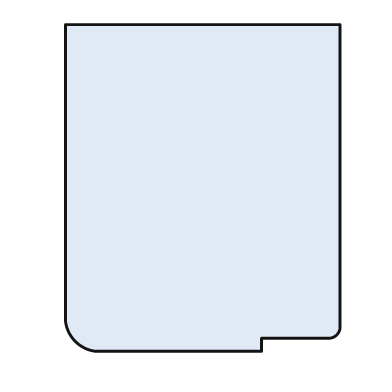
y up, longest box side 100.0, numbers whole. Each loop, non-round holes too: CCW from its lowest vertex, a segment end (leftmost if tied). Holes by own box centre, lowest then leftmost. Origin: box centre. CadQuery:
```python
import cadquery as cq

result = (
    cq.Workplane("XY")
    .moveTo(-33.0, -50.0)
    .lineTo(18.0, -50.0)
    .lineTo(18.0, -46.0)
    .lineTo(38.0, -46.0)
    .threePointArc((41.0, -45.0), (42.0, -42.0))
    .lineTo(42.0, 50.0)
    .lineTo(-42.0, 50.0)
    .lineTo(-42.0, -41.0)
    .threePointArc((-39.0, -47.0), (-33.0, -50.0))
    .close()
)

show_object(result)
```